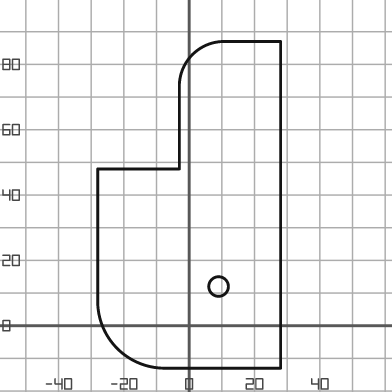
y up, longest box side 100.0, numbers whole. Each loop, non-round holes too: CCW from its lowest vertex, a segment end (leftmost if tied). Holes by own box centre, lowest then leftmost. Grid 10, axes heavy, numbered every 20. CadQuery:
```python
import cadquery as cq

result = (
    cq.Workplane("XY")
    .moveTo(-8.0, -13.0)
    .lineTo(28.0, -13.0)
    .lineTo(28.0, 87.0)
    .lineTo(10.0, 87.0)
    .threePointArc((1.0, 83.0), (-3.0, 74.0))
    .lineTo(-3.0, 48.0)
    .lineTo(-28.0, 48.0)
    .lineTo(-28.0, 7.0)
    .threePointArc((-22.0, -7.0), (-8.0, -13.0))
    .close()
    .moveTo(9.0, 12.0)
    .circle(3.0)
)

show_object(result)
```